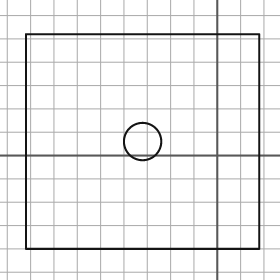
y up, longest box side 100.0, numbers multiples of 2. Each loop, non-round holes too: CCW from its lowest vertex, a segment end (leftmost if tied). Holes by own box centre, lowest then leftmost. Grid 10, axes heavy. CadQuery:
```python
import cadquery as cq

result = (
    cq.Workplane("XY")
    .moveTo(-82.0, -40.0)
    .lineTo(18.0, -40.0)
    .lineTo(18.0, 52.0)
    .lineTo(-82.0, 52.0)
    .close()
    .moveTo(-32.0, 6.0)
    .circle(8.0)
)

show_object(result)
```